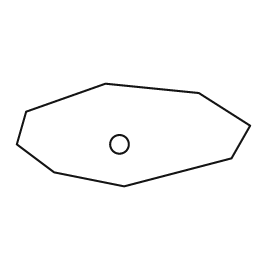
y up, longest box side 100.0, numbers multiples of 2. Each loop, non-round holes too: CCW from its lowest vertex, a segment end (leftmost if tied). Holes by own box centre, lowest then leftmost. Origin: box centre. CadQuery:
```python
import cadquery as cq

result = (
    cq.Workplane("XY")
    .moveTo(-4.0, -22.0)
    .lineTo(42.0, -10.0)
    .lineTo(50.0, 4.0)
    .lineTo(28.0, 18.0)
    .lineTo(-12.0, 22.0)
    .lineTo(-46.0, 10.0)
    .lineTo(-50.0, -4.0)
    .lineTo(-34.0, -16.0)
    .close()
    .moveTo(-6.0, -4.0)
    .circle(4.0)
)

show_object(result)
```